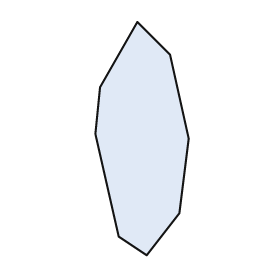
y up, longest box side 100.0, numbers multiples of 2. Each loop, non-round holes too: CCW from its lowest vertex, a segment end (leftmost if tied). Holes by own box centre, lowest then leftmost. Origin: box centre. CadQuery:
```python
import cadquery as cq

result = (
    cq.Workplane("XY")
    .moveTo(2.0, -50.0)
    .lineTo(16.0, -32.0)
    .lineTo(20.0, 0.0)
    .lineTo(12.0, 36.0)
    .lineTo(-2.0, 50.0)
    .lineTo(-18.0, 22.0)
    .lineTo(-20.0, 2.0)
    .lineTo(-10.0, -42.0)
    .close()
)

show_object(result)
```